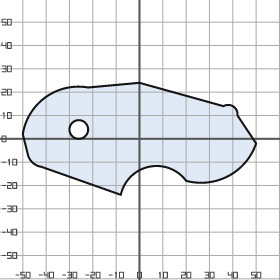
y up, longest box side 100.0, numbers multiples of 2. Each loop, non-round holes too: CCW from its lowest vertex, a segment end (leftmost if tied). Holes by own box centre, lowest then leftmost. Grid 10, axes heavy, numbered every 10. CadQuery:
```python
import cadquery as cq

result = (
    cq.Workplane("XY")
    .moveTo(-8.0, -24.0)
    .threePointArc((4.0, -12.0), (20.0, -18.0))
    .threePointArc((38.0, -16.0), (50.0, -2.0))
    .lineTo(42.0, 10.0)
    .threePointArc((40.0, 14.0), (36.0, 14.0))
    .lineTo(0.0, 24.0)
    .lineTo(-22.0, 22.0)
    .threePointArc((-40.0, 18.0), (-50.0, 2.0))
    .lineTo(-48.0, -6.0)
    .threePointArc((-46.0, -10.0), (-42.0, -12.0))
    .close()
    .moveTo(-26.0, 4.0)
    .circle(4.0)
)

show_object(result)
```